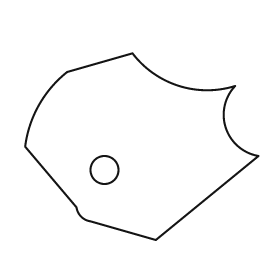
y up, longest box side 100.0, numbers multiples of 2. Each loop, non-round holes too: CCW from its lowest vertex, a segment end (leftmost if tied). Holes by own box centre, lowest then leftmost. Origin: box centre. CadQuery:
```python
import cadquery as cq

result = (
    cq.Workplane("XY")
    .moveTo(6.0, -40.0)
    .lineTo(50.0, -4.0)
    .threePointArc((36.0, 8.0), (40.0, 26.0))
    .threePointArc((16.0, 26.0), (-4.0, 40.0))
    .lineTo(-32.0, 32.0)
    .threePointArc((-44.0, 18.0), (-50.0, 0.0))
    .lineTo(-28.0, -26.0)
    .threePointArc((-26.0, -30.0), (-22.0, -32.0))
    .close()
    .moveTo(-16.0, -10.0)
    .circle(6.0)
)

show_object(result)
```